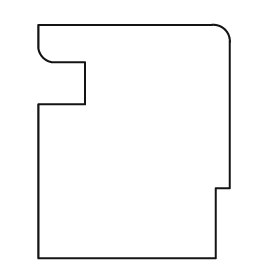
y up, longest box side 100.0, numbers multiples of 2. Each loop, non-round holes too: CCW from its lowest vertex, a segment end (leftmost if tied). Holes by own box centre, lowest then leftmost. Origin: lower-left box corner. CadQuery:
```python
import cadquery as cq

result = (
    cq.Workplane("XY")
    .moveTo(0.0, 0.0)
    .lineTo(76.0, 0.0)
    .lineTo(76.0, 30.0)
    .lineTo(82.0, 30.0)
    .lineTo(82.0, 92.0)
    .threePointArc((80.0, 98.0), (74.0, 100.0))
    .lineTo(0.0, 100.0)
    .lineTo(0.0, 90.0)
    .threePointArc((2.0, 86.0), (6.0, 84.0))
    .lineTo(20.0, 84.0)
    .lineTo(20.0, 66.0)
    .lineTo(0.0, 66.0)
    .close()
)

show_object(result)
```